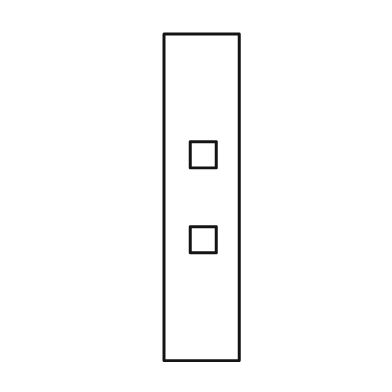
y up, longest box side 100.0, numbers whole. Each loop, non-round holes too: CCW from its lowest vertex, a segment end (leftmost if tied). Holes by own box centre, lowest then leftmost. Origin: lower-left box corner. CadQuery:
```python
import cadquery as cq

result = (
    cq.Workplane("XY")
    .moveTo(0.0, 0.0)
    .lineTo(23.0, 0.0)
    .lineTo(23.0, 100.0)
    .lineTo(0.0, 100.0)
    .close()
    .moveTo(8.0, 33.0)
    .lineTo(16.0, 33.0)
    .lineTo(16.0, 41.0)
    .lineTo(8.0, 41.0)
    .close()
    .moveTo(8.0, 59.0)
    .lineTo(16.0, 59.0)
    .lineTo(16.0, 67.0)
    .lineTo(8.0, 67.0)
    .close()
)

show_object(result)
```